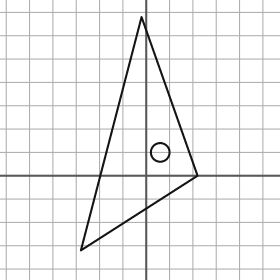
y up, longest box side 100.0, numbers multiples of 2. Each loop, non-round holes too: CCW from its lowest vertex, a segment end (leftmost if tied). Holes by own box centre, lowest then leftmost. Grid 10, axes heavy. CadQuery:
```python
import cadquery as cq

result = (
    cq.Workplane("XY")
    .moveTo(-28.0, -32.0)
    .lineTo(22.0, 0.0)
    .lineTo(-2.0, 68.0)
    .close()
    .moveTo(6.0, 10.0)
    .circle(4.0)
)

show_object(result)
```